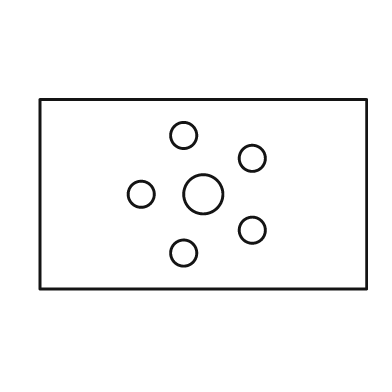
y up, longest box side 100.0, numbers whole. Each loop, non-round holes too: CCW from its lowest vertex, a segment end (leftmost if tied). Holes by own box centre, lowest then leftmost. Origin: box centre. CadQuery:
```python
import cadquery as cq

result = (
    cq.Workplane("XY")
    .moveTo(-50.0, -29.0)
    .lineTo(50.0, -29.0)
    .lineTo(50.0, 29.0)
    .lineTo(-50.0, 29.0)
    .close()
    .moveTo(-6.0, -18.0)
    .circle(4.0)
    .moveTo(15.0, -11.0)
    .circle(4.0)
    .moveTo(-19.0, 0.0)
    .circle(4.0)
    .moveTo(0.0, 0.0)
    .circle(6.0)
    .moveTo(15.0, 11.0)
    .circle(4.0)
    .moveTo(-6.0, 18.0)
    .circle(4.0)
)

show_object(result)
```